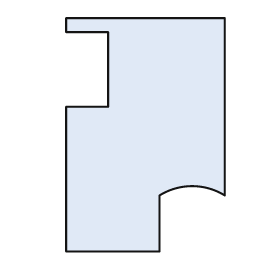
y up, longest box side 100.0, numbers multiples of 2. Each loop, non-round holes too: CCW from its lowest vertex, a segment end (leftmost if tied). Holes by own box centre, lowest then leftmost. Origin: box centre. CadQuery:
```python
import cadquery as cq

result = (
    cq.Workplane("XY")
    .moveTo(-34.0, -50.0)
    .lineTo(6.0, -50.0)
    .lineTo(6.0, -26.0)
    .threePointArc((20.0, -22.0), (34.0, -26.0))
    .lineTo(34.0, 50.0)
    .lineTo(-34.0, 50.0)
    .lineTo(-34.0, 44.0)
    .lineTo(-16.0, 44.0)
    .lineTo(-16.0, 12.0)
    .lineTo(-34.0, 12.0)
    .close()
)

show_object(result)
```